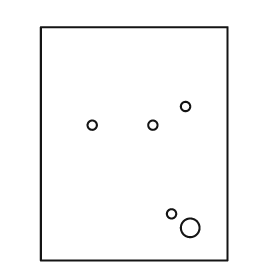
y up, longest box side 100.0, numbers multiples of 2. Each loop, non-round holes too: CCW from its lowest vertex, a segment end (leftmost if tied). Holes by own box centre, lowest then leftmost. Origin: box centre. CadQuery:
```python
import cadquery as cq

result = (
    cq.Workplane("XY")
    .moveTo(-40.0, -50.0)
    .lineTo(40.0, -50.0)
    .lineTo(40.0, 50.0)
    .lineTo(-40.0, 50.0)
    .close()
    .moveTo(24.0, -36.0)
    .circle(4.0)
    .moveTo(16.0, -30.0)
    .circle(2.0)
    .moveTo(-18.0, 8.0)
    .circle(2.0)
    .moveTo(8.0, 8.0)
    .circle(2.0)
    .moveTo(22.0, 16.0)
    .circle(2.0)
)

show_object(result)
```